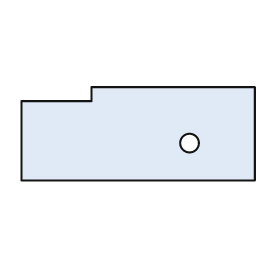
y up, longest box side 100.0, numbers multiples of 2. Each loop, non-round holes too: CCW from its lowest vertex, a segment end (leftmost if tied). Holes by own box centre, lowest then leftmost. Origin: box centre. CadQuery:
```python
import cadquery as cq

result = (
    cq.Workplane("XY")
    .moveTo(-50.0, -20.0)
    .lineTo(50.0, -20.0)
    .lineTo(50.0, 20.0)
    .lineTo(-20.0, 20.0)
    .lineTo(-20.0, 14.0)
    .lineTo(-50.0, 14.0)
    .close()
    .moveTo(22.0, -4.0)
    .circle(4.0)
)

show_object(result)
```